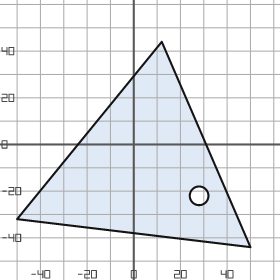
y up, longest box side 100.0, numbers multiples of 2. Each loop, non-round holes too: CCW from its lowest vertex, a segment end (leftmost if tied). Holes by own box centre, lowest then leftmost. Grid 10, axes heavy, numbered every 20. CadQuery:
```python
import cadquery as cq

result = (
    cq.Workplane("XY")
    .moveTo(50.0, -44.0)
    .lineTo(12.0, 44.0)
    .lineTo(-50.0, -32.0)
    .close()
    .moveTo(28.0, -22.0)
    .circle(4.0)
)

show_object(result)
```